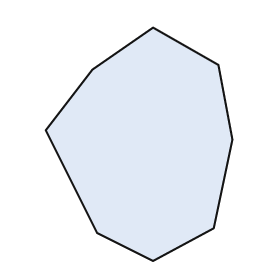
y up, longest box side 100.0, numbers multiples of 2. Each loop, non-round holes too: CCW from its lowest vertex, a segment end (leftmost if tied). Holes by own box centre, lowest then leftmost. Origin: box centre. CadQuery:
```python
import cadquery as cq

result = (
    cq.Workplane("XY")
    .moveTo(6.0, -50.0)
    .lineTo(32.0, -36.0)
    .lineTo(40.0, 2.0)
    .lineTo(34.0, 34.0)
    .lineTo(6.0, 50.0)
    .lineTo(-20.0, 32.0)
    .lineTo(-40.0, 6.0)
    .lineTo(-18.0, -38.0)
    .close()
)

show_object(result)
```